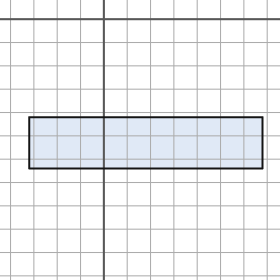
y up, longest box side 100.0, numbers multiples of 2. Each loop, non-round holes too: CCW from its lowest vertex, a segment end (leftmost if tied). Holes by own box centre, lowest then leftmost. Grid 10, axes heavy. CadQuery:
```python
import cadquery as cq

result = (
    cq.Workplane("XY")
    .moveTo(-32.0, -64.0)
    .lineTo(68.0, -64.0)
    .lineTo(68.0, -42.0)
    .lineTo(-32.0, -42.0)
    .close()
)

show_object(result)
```